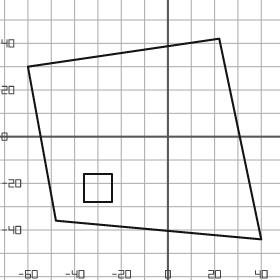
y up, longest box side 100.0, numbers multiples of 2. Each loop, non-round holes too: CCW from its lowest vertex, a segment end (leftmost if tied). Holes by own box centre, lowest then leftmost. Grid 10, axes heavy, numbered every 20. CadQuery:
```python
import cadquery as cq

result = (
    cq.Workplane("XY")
    .moveTo(40.0, -44.0)
    .lineTo(22.0, 42.0)
    .lineTo(-60.0, 30.0)
    .lineTo(-48.0, -36.0)
    .close()
    .moveTo(-36.0, -28.0)
    .lineTo(-24.0, -28.0)
    .lineTo(-24.0, -16.0)
    .lineTo(-36.0, -16.0)
    .close()
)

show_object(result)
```